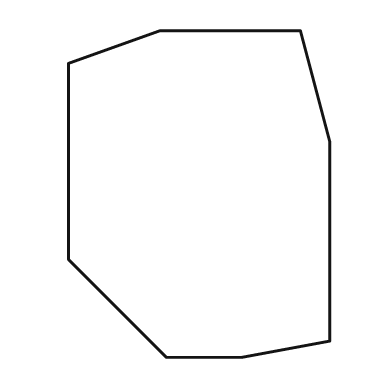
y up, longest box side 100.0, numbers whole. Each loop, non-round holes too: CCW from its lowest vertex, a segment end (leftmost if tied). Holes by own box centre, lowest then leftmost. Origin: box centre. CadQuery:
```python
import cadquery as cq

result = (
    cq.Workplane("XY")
    .moveTo(-10.0, -50.0)
    .lineTo(13.0, -50.0)
    .lineTo(40.0, -45.0)
    .lineTo(40.0, 16.0)
    .lineTo(31.0, 50.0)
    .lineTo(-12.0, 50.0)
    .lineTo(-40.0, 40.0)
    .lineTo(-40.0, -20.0)
    .close()
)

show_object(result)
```